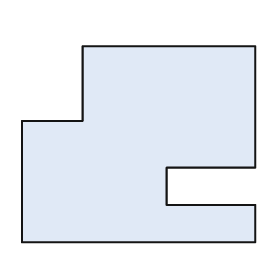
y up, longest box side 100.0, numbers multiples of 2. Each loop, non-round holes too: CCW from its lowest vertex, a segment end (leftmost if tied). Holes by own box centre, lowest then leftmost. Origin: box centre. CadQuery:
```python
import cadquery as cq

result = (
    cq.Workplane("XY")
    .moveTo(-50.0, -42.0)
    .lineTo(50.0, -42.0)
    .lineTo(50.0, -26.0)
    .lineTo(12.0, -26.0)
    .lineTo(12.0, -10.0)
    .lineTo(50.0, -10.0)
    .lineTo(50.0, 42.0)
    .lineTo(-24.0, 42.0)
    .lineTo(-24.0, 10.0)
    .lineTo(-50.0, 10.0)
    .close()
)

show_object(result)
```